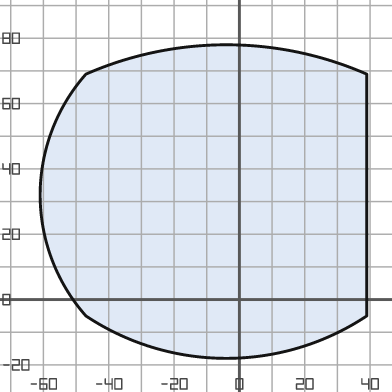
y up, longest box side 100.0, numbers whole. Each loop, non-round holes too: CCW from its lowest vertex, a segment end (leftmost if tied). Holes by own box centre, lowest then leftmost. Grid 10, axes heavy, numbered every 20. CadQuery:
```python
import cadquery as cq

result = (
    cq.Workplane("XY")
    .moveTo(-47.0, -5.0)
    .threePointArc((-4.0, -18.0), (39.0, -5.0))
    .lineTo(39.0, 69.0)
    .threePointArc((-4.0, 78.0), (-47.0, 69.0))
    .threePointArc((-61.0, 32.0), (-47.0, -5.0))
    .close()
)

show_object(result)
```